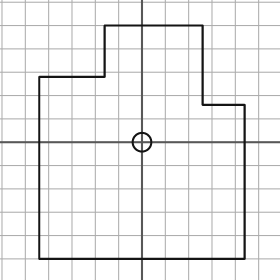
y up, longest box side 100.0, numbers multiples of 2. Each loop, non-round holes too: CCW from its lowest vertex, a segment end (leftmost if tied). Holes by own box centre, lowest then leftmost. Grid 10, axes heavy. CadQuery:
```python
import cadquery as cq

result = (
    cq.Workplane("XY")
    .moveTo(-44.0, -50.0)
    .lineTo(44.0, -50.0)
    .lineTo(44.0, 16.0)
    .lineTo(26.0, 16.0)
    .lineTo(26.0, 50.0)
    .lineTo(-16.0, 50.0)
    .lineTo(-16.0, 28.0)
    .lineTo(-44.0, 28.0)
    .close()
    .moveTo(0.0, 0.0)
    .circle(4.0)
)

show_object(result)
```